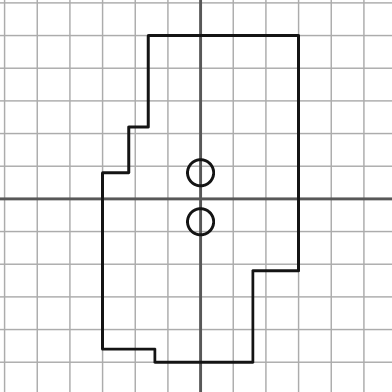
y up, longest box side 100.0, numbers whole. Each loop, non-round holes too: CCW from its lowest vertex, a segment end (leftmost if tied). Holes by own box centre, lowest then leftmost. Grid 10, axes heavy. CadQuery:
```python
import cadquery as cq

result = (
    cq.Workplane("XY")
    .moveTo(-14.0, -50.0)
    .lineTo(16.0, -50.0)
    .lineTo(16.0, -22.0)
    .lineTo(30.0, -22.0)
    .lineTo(30.0, 50.0)
    .lineTo(-16.0, 50.0)
    .lineTo(-16.0, 22.0)
    .lineTo(-22.0, 22.0)
    .lineTo(-22.0, 8.0)
    .lineTo(-30.0, 8.0)
    .lineTo(-30.0, -46.0)
    .lineTo(-14.0, -46.0)
    .close()
    .moveTo(0.0, -7.0)
    .circle(4.0)
    .moveTo(0.0, 8.0)
    .circle(4.0)
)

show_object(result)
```